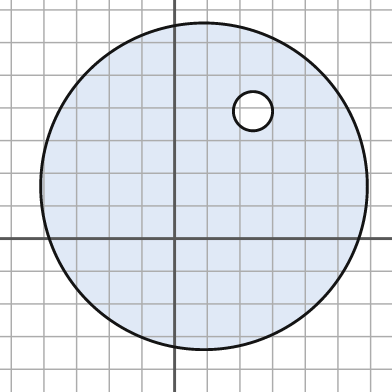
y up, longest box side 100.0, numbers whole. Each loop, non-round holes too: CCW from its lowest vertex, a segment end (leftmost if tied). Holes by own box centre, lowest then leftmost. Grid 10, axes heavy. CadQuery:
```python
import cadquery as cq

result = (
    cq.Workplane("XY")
    .moveTo(9.0, 16.0)
    .circle(50.0)
    .moveTo(24.0, 39.0)
    .circle(6.0)
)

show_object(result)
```